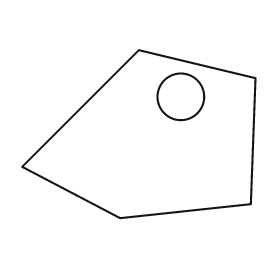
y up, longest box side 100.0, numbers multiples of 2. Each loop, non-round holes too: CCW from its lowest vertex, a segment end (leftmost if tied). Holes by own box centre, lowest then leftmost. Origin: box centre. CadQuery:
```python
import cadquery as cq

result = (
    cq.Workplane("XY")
    .moveTo(-8.0, -36.0)
    .lineTo(48.0, -30.0)
    .lineTo(50.0, 24.0)
    .lineTo(0.0, 36.0)
    .lineTo(-50.0, -14.0)
    .close()
    .moveTo(18.0, 16.0)
    .circle(10.0)
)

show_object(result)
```